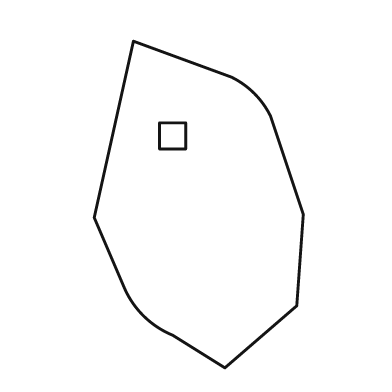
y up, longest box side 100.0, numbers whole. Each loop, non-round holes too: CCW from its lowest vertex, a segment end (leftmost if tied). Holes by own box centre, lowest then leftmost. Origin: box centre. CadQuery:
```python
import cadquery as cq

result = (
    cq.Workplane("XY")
    .moveTo(8.0, -50.0)
    .lineTo(30.0, -31.0)
    .lineTo(32.0, -3.0)
    .lineTo(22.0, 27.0)
    .threePointArc((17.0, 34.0), (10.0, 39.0))
    .lineTo(-20.0, 50.0)
    .lineTo(-32.0, -4.0)
    .lineTo(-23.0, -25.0)
    .threePointArc((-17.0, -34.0), (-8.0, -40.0))
    .close()
    .moveTo(-12.0, 17.0)
    .lineTo(-4.0, 17.0)
    .lineTo(-4.0, 25.0)
    .lineTo(-12.0, 25.0)
    .close()
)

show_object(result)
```